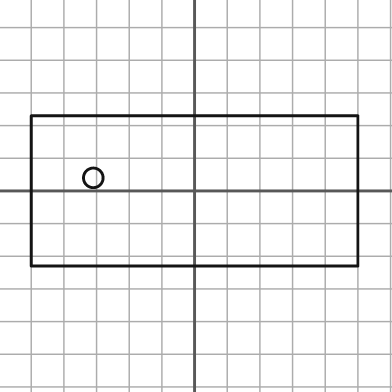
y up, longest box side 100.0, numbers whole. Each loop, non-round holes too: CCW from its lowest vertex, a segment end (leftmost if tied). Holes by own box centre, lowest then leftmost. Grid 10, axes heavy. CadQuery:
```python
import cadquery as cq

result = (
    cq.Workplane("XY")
    .moveTo(-50.0, -23.0)
    .lineTo(50.0, -23.0)
    .lineTo(50.0, 23.0)
    .lineTo(-50.0, 23.0)
    .close()
    .moveTo(-31.0, 4.0)
    .circle(3.0)
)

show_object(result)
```